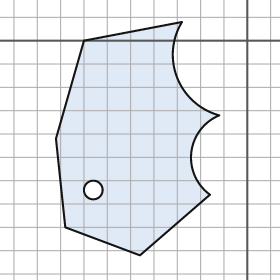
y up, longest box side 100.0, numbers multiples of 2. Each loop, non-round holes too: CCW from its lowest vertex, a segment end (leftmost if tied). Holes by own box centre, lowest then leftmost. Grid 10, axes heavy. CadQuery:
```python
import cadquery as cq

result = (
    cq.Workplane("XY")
    .moveTo(-46.0, -92.0)
    .lineTo(-16.0, -66.0)
    .threePointArc((-24.0, -48.0), (-12.0, -32.0))
    .threePointArc((-30.0, -16.0), (-28.0, 8.0))
    .lineTo(-70.0, 0.0)
    .lineTo(-82.0, -42.0)
    .lineTo(-78.0, -80.0)
    .close()
    .moveTo(-66.0, -64.0)
    .circle(4.0)
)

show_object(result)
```